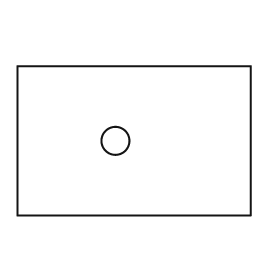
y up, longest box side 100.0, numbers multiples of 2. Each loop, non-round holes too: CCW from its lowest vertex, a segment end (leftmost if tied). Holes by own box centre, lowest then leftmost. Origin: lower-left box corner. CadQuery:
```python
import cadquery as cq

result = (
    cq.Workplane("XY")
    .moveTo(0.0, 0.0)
    .lineTo(100.0, 0.0)
    .lineTo(100.0, 64.0)
    .lineTo(0.0, 64.0)
    .close()
    .moveTo(42.0, 32.0)
    .circle(6.0)
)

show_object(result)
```